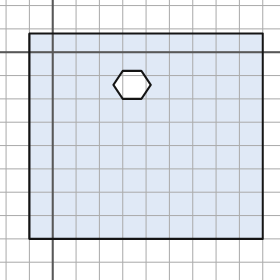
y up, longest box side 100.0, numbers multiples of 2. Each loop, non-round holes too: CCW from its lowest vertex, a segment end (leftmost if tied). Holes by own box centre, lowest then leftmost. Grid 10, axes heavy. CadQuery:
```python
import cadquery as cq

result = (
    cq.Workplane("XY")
    .moveTo(-10.0, -80.0)
    .lineTo(90.0, -80.0)
    .lineTo(90.0, 8.0)
    .lineTo(-10.0, 8.0)
    .close()
    .moveTo(30.0, -20.0)
    .lineTo(38.0, -20.0)
    .lineTo(42.0, -14.0)
    .lineTo(38.0, -8.0)
    .lineTo(30.0, -8.0)
    .lineTo(26.0, -14.0)
    .close()
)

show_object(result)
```